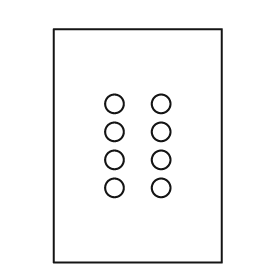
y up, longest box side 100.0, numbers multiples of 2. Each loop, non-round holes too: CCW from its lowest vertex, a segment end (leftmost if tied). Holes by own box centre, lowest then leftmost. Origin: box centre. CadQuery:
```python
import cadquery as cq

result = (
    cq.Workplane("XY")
    .moveTo(-36.0, -50.0)
    .lineTo(36.0, -50.0)
    .lineTo(36.0, 50.0)
    .lineTo(-36.0, 50.0)
    .close()
    .moveTo(-10.0, -18.0)
    .circle(4.0)
    .moveTo(10.0, -18.0)
    .circle(4.0)
    .moveTo(-10.0, -6.0)
    .circle(4.0)
    .moveTo(10.0, -6.0)
    .circle(4.0)
    .moveTo(-10.0, 6.0)
    .circle(4.0)
    .moveTo(10.0, 6.0)
    .circle(4.0)
    .moveTo(-10.0, 18.0)
    .circle(4.0)
    .moveTo(10.0, 18.0)
    .circle(4.0)
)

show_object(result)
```